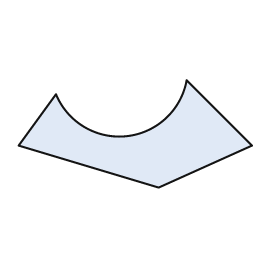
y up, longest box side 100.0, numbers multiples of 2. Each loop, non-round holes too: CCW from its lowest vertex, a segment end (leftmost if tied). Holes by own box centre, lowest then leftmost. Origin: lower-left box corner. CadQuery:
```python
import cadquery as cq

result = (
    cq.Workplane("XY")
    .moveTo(60.0, 0.0)
    .lineTo(100.0, 18.0)
    .lineTo(72.0, 46.0)
    .threePointArc((46.0, 22.0), (16.0, 40.0))
    .lineTo(0.0, 18.0)
    .close()
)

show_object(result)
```